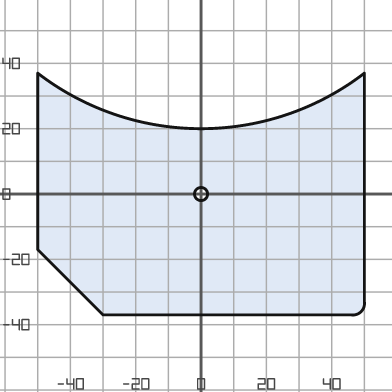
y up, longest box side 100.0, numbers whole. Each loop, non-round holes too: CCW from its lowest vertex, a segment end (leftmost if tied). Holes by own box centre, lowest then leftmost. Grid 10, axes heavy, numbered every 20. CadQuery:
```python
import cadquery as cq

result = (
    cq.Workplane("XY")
    .moveTo(-30.0, -37.0)
    .lineTo(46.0, -37.0)
    .threePointArc((49.0, -36.0), (50.0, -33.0))
    .lineTo(50.0, 37.0)
    .threePointArc((0.0, 20.0), (-50.0, 37.0))
    .lineTo(-50.0, -17.0)
    .close()
    .moveTo(0.0, 0.0)
    .circle(2.0)
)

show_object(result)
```